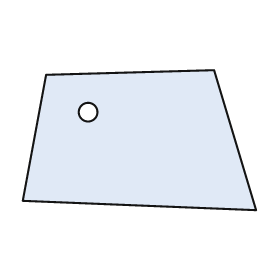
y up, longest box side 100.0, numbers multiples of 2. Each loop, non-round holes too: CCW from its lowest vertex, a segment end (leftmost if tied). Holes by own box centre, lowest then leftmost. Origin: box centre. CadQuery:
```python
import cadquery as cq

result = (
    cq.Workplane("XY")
    .moveTo(50.0, -30.0)
    .lineTo(32.0, 30.0)
    .lineTo(-40.0, 28.0)
    .lineTo(-50.0, -26.0)
    .close()
    .moveTo(-22.0, 12.0)
    .circle(4.0)
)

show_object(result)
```